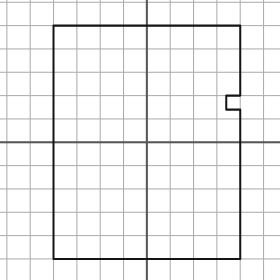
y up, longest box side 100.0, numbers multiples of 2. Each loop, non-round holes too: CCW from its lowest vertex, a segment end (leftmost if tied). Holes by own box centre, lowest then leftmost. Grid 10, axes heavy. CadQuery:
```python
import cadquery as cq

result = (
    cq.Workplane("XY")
    .moveTo(-40.0, -50.0)
    .lineTo(40.0, -50.0)
    .lineTo(40.0, 14.0)
    .lineTo(34.0, 14.0)
    .lineTo(34.0, 20.0)
    .lineTo(40.0, 20.0)
    .lineTo(40.0, 50.0)
    .lineTo(-40.0, 50.0)
    .close()
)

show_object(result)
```